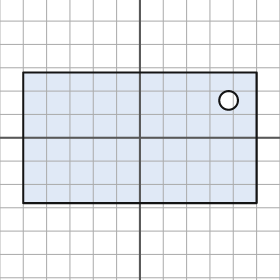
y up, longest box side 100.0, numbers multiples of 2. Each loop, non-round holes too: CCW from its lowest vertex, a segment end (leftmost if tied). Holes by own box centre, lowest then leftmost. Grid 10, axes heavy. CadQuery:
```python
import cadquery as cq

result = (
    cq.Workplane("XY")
    .moveTo(-50.0, -28.0)
    .lineTo(50.0, -28.0)
    .lineTo(50.0, 28.0)
    .lineTo(-50.0, 28.0)
    .close()
    .moveTo(38.0, 16.0)
    .circle(4.0)
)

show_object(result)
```